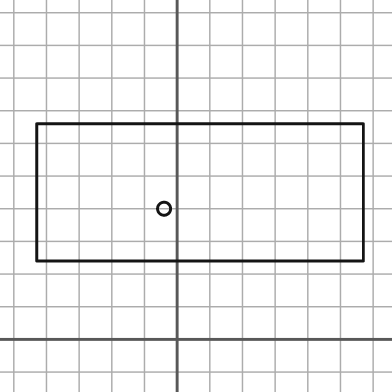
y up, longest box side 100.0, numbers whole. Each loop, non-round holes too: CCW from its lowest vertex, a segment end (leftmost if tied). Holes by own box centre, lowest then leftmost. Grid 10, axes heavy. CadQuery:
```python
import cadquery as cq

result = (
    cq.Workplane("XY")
    .moveTo(-43.0, 24.0)
    .lineTo(57.0, 24.0)
    .lineTo(57.0, 66.0)
    .lineTo(-43.0, 66.0)
    .close()
    .moveTo(-4.0, 40.0)
    .circle(2.0)
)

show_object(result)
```